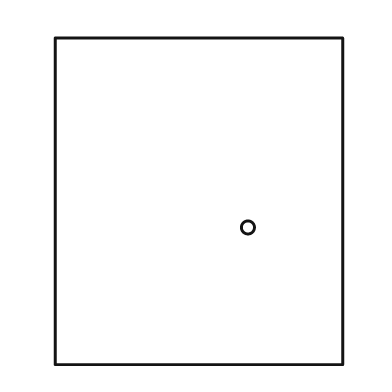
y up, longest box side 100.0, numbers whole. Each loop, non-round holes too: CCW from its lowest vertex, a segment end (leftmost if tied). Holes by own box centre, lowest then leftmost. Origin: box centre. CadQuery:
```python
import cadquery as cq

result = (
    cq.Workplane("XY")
    .moveTo(-44.0, -50.0)
    .lineTo(44.0, -50.0)
    .lineTo(44.0, 50.0)
    .lineTo(-44.0, 50.0)
    .close()
    .moveTo(15.0, -8.0)
    .circle(2.0)
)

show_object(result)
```